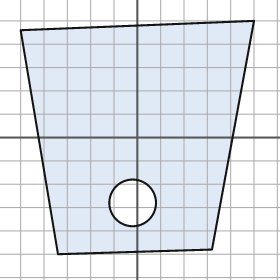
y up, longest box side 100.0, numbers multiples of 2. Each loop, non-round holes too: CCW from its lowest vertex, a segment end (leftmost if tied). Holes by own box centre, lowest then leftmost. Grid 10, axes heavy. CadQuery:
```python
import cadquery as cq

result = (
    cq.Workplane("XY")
    .moveTo(-34.0, -50.0)
    .lineTo(32.0, -48.0)
    .lineTo(50.0, 50.0)
    .lineTo(-50.0, 46.0)
    .close()
    .moveTo(-2.0, -28.0)
    .circle(10.0)
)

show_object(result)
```